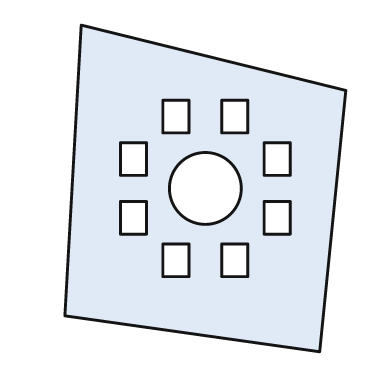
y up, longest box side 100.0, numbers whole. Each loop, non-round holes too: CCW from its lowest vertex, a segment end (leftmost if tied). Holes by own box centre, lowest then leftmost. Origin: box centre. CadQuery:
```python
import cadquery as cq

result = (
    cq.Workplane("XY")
    .moveTo(35.0, -50.0)
    .lineTo(43.0, 30.0)
    .lineTo(-38.0, 50.0)
    .lineTo(-43.0, -39.0)
    .close()
    .moveTo(-13.0, -27.0)
    .lineTo(-5.0, -27.0)
    .lineTo(-5.0, -17.0)
    .lineTo(-13.0, -17.0)
    .close()
    .moveTo(5.0, -27.0)
    .lineTo(13.0, -27.0)
    .lineTo(13.0, -17.0)
    .lineTo(5.0, -17.0)
    .close()
    .moveTo(-26.0, -14.0)
    .lineTo(-18.0, -14.0)
    .lineTo(-18.0, -4.0)
    .lineTo(-26.0, -4.0)
    .close()
    .moveTo(18.0, -14.0)
    .lineTo(26.0, -14.0)
    .lineTo(26.0, -4.0)
    .lineTo(18.0, -4.0)
    .close()
    .moveTo(0.0, 0.0)
    .circle(11.0)
    .moveTo(-26.0, 4.0)
    .lineTo(-18.0, 4.0)
    .lineTo(-18.0, 14.0)
    .lineTo(-26.0, 14.0)
    .close()
    .moveTo(18.0, 4.0)
    .lineTo(26.0, 4.0)
    .lineTo(26.0, 14.0)
    .lineTo(18.0, 14.0)
    .close()
    .moveTo(-13.0, 17.0)
    .lineTo(-5.0, 17.0)
    .lineTo(-5.0, 27.0)
    .lineTo(-13.0, 27.0)
    .close()
    .moveTo(5.0, 17.0)
    .lineTo(13.0, 17.0)
    .lineTo(13.0, 27.0)
    .lineTo(5.0, 27.0)
    .close()
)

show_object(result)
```